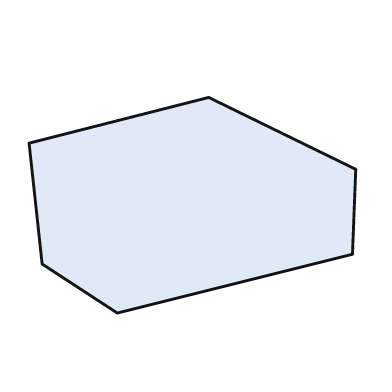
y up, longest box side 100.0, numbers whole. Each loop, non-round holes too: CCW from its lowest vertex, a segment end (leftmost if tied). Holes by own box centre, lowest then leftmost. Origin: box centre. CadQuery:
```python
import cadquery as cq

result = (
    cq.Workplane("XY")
    .moveTo(-23.0, -33.0)
    .lineTo(49.0, -15.0)
    .lineTo(50.0, 11.0)
    .lineTo(5.0, 33.0)
    .lineTo(-50.0, 19.0)
    .lineTo(-46.0, -18.0)
    .close()
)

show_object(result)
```